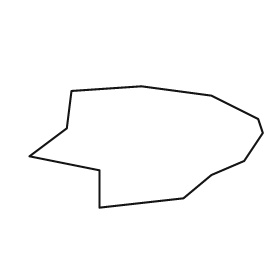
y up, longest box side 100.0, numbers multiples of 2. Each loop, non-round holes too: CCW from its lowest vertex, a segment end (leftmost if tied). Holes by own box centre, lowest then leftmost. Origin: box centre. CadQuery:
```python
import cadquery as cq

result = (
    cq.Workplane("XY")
    .moveTo(-20.0, -26.0)
    .lineTo(16.0, -22.0)
    .lineTo(28.0, -12.0)
    .lineTo(42.0, -6.0)
    .lineTo(50.0, 6.0)
    .lineTo(48.0, 12.0)
    .lineTo(28.0, 22.0)
    .lineTo(-2.0, 26.0)
    .lineTo(-32.0, 24.0)
    .lineTo(-34.0, 8.0)
    .lineTo(-50.0, -4.0)
    .lineTo(-20.0, -10.0)
    .close()
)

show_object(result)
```